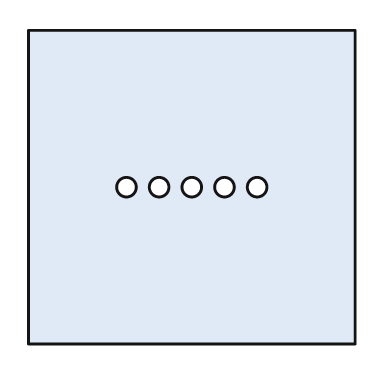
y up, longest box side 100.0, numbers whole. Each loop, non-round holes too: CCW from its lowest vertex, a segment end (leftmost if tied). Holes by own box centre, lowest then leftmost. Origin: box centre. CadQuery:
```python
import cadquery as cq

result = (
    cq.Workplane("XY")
    .moveTo(-50.0, -48.0)
    .lineTo(50.0, -48.0)
    .lineTo(50.0, 48.0)
    .lineTo(-50.0, 48.0)
    .close()
    .moveTo(-20.0, 0.0)
    .circle(3.0)
    .moveTo(-10.0, 0.0)
    .circle(3.0)
    .moveTo(0.0, 0.0)
    .circle(3.0)
    .moveTo(10.0, 0.0)
    .circle(3.0)
    .moveTo(20.0, 0.0)
    .circle(3.0)
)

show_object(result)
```